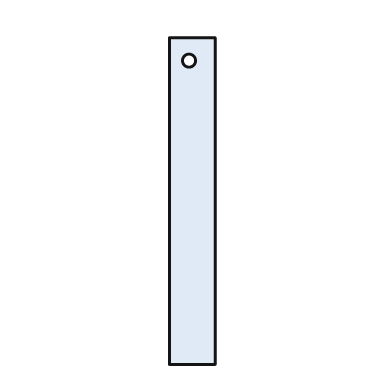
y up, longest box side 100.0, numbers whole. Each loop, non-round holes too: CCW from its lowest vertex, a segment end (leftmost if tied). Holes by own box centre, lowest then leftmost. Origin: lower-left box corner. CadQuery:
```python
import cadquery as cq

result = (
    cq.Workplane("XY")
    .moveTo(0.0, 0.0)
    .lineTo(14.0, 0.0)
    .lineTo(14.0, 100.0)
    .lineTo(0.0, 100.0)
    .close()
    .moveTo(6.0, 93.0)
    .circle(2.0)
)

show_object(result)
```